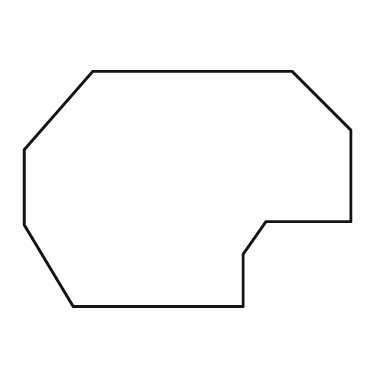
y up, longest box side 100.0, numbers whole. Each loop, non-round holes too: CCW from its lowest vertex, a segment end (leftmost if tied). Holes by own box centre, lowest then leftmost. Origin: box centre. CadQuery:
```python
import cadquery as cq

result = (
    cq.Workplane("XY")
    .moveTo(-35.0, -36.0)
    .lineTo(17.0, -36.0)
    .lineTo(17.0, -20.0)
    .lineTo(24.0, -10.0)
    .lineTo(50.0, -10.0)
    .lineTo(50.0, 18.0)
    .lineTo(32.0, 36.0)
    .lineTo(-29.0, 36.0)
    .lineTo(-50.0, 12.0)
    .lineTo(-50.0, -11.0)
    .close()
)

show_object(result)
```